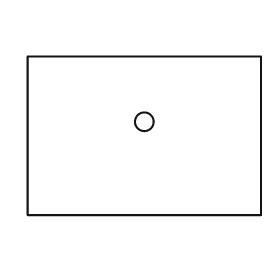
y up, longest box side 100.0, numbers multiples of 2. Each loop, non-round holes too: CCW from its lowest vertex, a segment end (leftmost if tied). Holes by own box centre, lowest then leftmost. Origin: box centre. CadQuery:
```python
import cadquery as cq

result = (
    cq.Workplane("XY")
    .moveTo(-50.0, -34.0)
    .lineTo(50.0, -34.0)
    .lineTo(50.0, 34.0)
    .lineTo(-50.0, 34.0)
    .close()
    .moveTo(0.0, 6.0)
    .circle(4.0)
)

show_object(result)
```